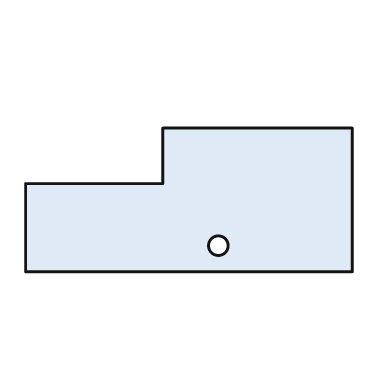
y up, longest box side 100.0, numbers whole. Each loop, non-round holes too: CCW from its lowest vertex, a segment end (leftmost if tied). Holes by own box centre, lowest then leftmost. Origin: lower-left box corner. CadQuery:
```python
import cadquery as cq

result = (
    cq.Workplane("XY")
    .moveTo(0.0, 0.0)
    .lineTo(100.0, 0.0)
    .lineTo(100.0, 44.0)
    .lineTo(42.0, 44.0)
    .lineTo(42.0, 27.0)
    .lineTo(0.0, 27.0)
    .close()
    .moveTo(59.0, 8.0)
    .circle(3.0)
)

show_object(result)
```